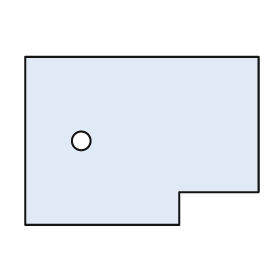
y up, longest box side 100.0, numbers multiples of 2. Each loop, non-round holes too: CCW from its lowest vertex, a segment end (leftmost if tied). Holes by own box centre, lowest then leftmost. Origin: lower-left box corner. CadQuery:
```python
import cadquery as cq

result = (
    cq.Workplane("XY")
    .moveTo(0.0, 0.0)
    .lineTo(66.0, 0.0)
    .lineTo(66.0, 14.0)
    .lineTo(100.0, 14.0)
    .lineTo(100.0, 72.0)
    .lineTo(0.0, 72.0)
    .close()
    .moveTo(24.0, 36.0)
    .circle(4.0)
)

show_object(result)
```